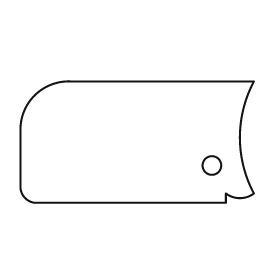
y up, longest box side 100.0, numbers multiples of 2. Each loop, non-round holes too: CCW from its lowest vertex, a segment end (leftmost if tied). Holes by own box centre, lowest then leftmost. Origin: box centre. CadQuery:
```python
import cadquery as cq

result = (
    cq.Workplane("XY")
    .moveTo(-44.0, -26.0)
    .lineTo(38.0, -26.0)
    .lineTo(38.0, -22.0)
    .threePointArc((44.0, -24.0), (50.0, -22.0))
    .threePointArc((44.0, 2.0), (50.0, 26.0))
    .lineTo(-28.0, 26.0)
    .threePointArc((-44.0, 20.0), (-50.0, 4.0))
    .lineTo(-50.0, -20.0)
    .threePointArc((-48.0, -24.0), (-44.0, -26.0))
    .close()
    .moveTo(32.0, -10.0)
    .circle(4.0)
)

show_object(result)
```